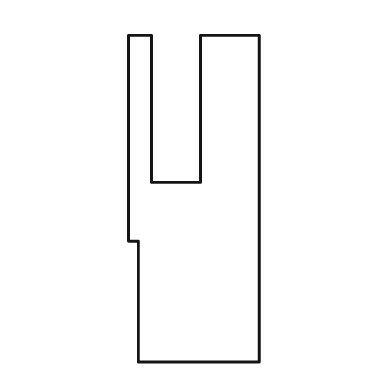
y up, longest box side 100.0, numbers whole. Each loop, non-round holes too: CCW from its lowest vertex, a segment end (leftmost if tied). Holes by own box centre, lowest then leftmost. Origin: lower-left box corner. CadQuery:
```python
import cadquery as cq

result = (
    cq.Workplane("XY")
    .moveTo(3.0, 0.0)
    .lineTo(40.0, 0.0)
    .lineTo(40.0, 100.0)
    .lineTo(22.0, 100.0)
    .lineTo(22.0, 55.0)
    .lineTo(7.0, 55.0)
    .lineTo(7.0, 100.0)
    .lineTo(0.0, 100.0)
    .lineTo(0.0, 37.0)
    .lineTo(3.0, 37.0)
    .close()
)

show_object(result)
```